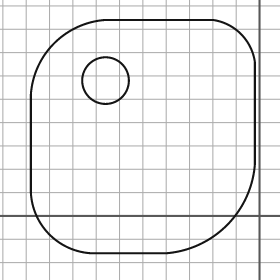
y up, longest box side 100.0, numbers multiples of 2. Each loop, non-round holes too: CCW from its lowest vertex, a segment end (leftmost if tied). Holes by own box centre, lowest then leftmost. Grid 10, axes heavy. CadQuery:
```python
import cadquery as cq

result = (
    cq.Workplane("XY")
    .moveTo(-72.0, -16.0)
    .lineTo(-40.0, -16.0)
    .threePointArc((-14.0, -4.0), (-2.0, 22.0))
    .lineTo(-2.0, 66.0)
    .threePointArc((-8.0, 78.0), (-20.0, 84.0))
    .lineTo(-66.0, 84.0)
    .threePointArc((-88.0, 74.0), (-98.0, 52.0))
    .lineTo(-98.0, 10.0)
    .threePointArc((-90.0, -8.0), (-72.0, -16.0))
    .close()
    .moveTo(-66.0, 58.0)
    .circle(10.0)
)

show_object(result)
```